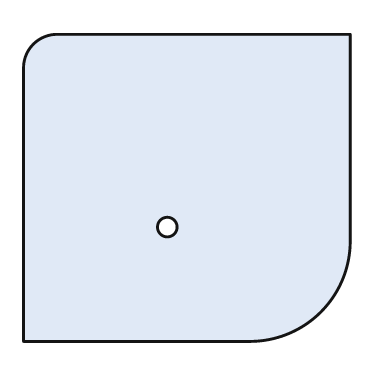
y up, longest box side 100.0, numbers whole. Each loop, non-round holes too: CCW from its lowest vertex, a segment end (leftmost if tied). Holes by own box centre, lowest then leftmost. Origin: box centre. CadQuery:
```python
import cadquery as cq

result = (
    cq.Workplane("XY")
    .moveTo(-50.0, -47.0)
    .lineTo(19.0, -47.0)
    .threePointArc((41.0, -38.0), (50.0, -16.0))
    .lineTo(50.0, 47.0)
    .lineTo(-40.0, 47.0)
    .threePointArc((-47.0, 44.0), (-50.0, 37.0))
    .close()
    .moveTo(-6.0, -12.0)
    .circle(3.0)
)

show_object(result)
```